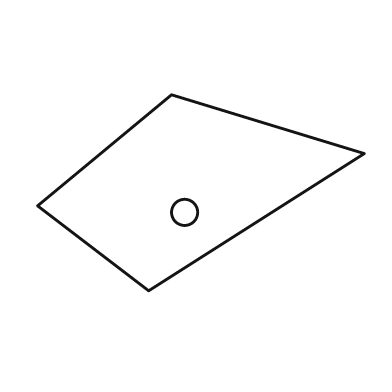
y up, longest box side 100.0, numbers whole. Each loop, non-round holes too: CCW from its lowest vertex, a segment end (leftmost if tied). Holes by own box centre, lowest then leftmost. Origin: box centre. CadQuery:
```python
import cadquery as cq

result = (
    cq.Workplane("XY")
    .moveTo(-16.0, -30.0)
    .lineTo(50.0, 12.0)
    .lineTo(-9.0, 30.0)
    .lineTo(-50.0, -4.0)
    .close()
    .moveTo(-5.0, -6.0)
    .circle(4.0)
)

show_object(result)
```